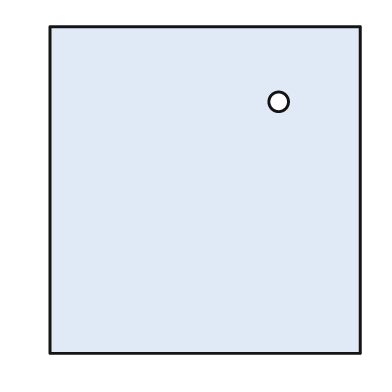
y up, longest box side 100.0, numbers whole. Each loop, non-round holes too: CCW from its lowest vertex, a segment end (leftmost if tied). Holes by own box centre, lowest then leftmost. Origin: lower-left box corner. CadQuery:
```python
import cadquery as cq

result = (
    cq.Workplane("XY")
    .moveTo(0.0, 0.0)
    .lineTo(95.0, 0.0)
    .lineTo(95.0, 100.0)
    .lineTo(0.0, 100.0)
    .close()
    .moveTo(70.0, 77.0)
    .circle(3.0)
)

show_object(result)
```